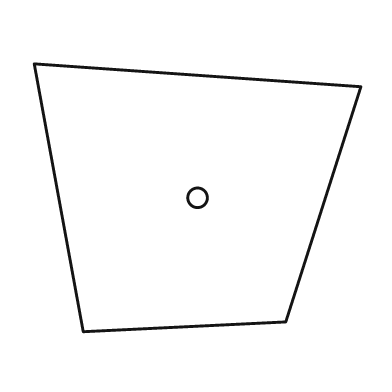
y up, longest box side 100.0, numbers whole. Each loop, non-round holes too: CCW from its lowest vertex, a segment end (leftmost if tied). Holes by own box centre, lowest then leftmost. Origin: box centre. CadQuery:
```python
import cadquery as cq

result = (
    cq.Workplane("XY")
    .moveTo(-35.0, -41.0)
    .lineTo(27.0, -38.0)
    .lineTo(50.0, 34.0)
    .lineTo(-50.0, 41.0)
    .close()
    .moveTo(0.0, 0.0)
    .circle(3.0)
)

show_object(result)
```